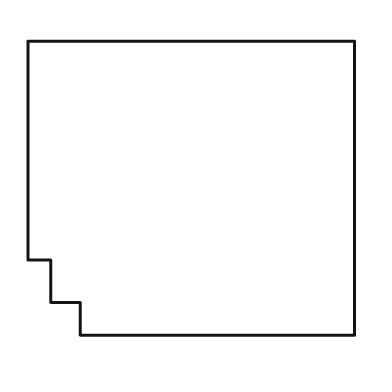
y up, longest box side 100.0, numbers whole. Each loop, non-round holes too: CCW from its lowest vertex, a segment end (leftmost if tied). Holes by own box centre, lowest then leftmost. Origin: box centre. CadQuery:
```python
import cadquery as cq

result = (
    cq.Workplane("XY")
    .moveTo(-34.0, -45.0)
    .lineTo(50.0, -45.0)
    .lineTo(50.0, 45.0)
    .lineTo(-50.0, 45.0)
    .lineTo(-50.0, -22.0)
    .lineTo(-43.0, -22.0)
    .lineTo(-43.0, -35.0)
    .lineTo(-34.0, -35.0)
    .close()
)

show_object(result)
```